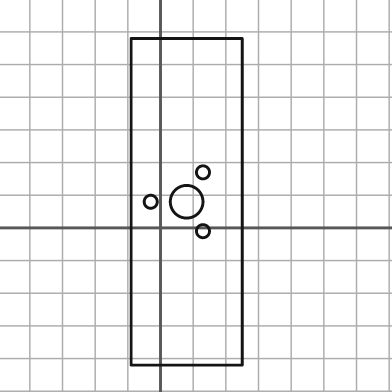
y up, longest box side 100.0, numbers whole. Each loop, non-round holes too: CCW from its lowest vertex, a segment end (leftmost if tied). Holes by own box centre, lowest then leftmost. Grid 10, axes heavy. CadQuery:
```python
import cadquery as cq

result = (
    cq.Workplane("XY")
    .moveTo(-9.0, -42.0)
    .lineTo(25.0, -42.0)
    .lineTo(25.0, 58.0)
    .lineTo(-9.0, 58.0)
    .close()
    .moveTo(13.0, -1.0)
    .circle(2.0)
    .moveTo(-3.0, 8.0)
    .circle(2.0)
    .moveTo(8.0, 8.0)
    .circle(5.0)
    .moveTo(13.0, 17.0)
    .circle(2.0)
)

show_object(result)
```